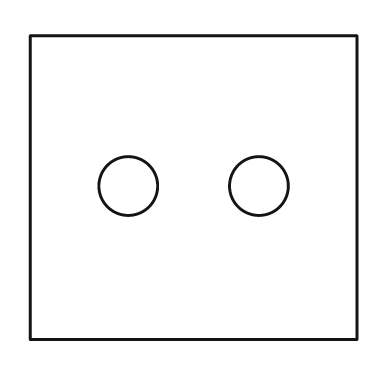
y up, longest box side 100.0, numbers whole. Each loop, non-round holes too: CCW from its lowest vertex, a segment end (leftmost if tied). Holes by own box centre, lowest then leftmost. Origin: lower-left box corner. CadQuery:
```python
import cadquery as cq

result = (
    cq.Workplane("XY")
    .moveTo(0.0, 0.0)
    .lineTo(100.0, 0.0)
    .lineTo(100.0, 93.0)
    .lineTo(0.0, 93.0)
    .close()
    .moveTo(30.0, 47.0)
    .circle(9.0)
    .moveTo(70.0, 47.0)
    .circle(9.0)
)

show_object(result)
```